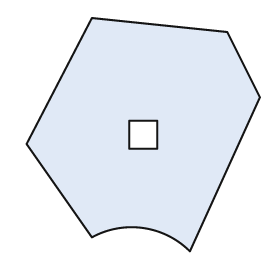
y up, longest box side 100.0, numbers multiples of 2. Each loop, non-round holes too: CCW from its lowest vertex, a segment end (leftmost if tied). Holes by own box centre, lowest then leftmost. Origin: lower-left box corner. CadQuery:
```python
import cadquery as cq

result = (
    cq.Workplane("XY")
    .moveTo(70.0, 0.0)
    .lineTo(100.0, 66.0)
    .lineTo(86.0, 94.0)
    .lineTo(28.0, 100.0)
    .lineTo(0.0, 46.0)
    .lineTo(28.0, 6.0)
    .threePointArc((50.0, 10.0), (70.0, 0.0))
    .close()
    .moveTo(44.0, 44.0)
    .lineTo(56.0, 44.0)
    .lineTo(56.0, 56.0)
    .lineTo(44.0, 56.0)
    .close()
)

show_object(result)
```